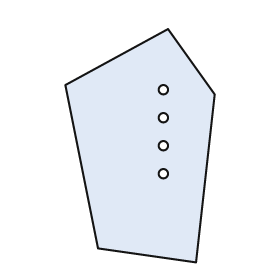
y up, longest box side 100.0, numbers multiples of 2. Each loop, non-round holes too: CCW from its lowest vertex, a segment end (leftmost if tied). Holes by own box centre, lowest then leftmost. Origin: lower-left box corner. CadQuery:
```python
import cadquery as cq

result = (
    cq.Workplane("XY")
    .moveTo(56.0, 0.0)
    .lineTo(64.0, 72.0)
    .lineTo(44.0, 100.0)
    .lineTo(0.0, 76.0)
    .lineTo(14.0, 6.0)
    .close()
    .moveTo(42.0, 38.0)
    .circle(2.0)
    .moveTo(42.0, 50.0)
    .circle(2.0)
    .moveTo(42.0, 62.0)
    .circle(2.0)
    .moveTo(42.0, 74.0)
    .circle(2.0)
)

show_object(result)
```